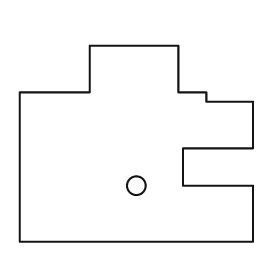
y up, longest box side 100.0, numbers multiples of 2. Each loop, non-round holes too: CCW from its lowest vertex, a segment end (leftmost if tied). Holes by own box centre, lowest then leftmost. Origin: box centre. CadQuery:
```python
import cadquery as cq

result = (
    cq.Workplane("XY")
    .moveTo(-50.0, -42.0)
    .lineTo(50.0, -42.0)
    .lineTo(50.0, -18.0)
    .lineTo(20.0, -18.0)
    .lineTo(20.0, -2.0)
    .lineTo(50.0, -2.0)
    .lineTo(50.0, 18.0)
    .lineTo(30.0, 18.0)
    .lineTo(30.0, 22.0)
    .lineTo(18.0, 22.0)
    .lineTo(18.0, 42.0)
    .lineTo(-20.0, 42.0)
    .lineTo(-20.0, 22.0)
    .lineTo(-50.0, 22.0)
    .close()
    .moveTo(0.0, -18.0)
    .circle(4.0)
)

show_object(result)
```